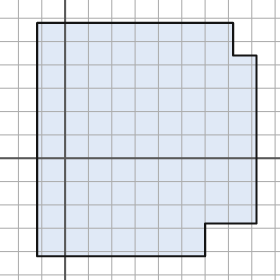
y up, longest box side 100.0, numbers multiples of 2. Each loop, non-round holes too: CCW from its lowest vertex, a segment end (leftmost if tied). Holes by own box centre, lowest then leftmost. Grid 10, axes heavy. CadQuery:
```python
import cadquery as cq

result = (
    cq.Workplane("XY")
    .moveTo(-12.0, -42.0)
    .lineTo(60.0, -42.0)
    .lineTo(60.0, -28.0)
    .lineTo(82.0, -28.0)
    .lineTo(82.0, 44.0)
    .lineTo(72.0, 44.0)
    .lineTo(72.0, 58.0)
    .lineTo(-12.0, 58.0)
    .close()
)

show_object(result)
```